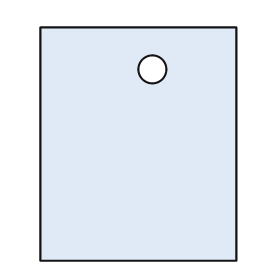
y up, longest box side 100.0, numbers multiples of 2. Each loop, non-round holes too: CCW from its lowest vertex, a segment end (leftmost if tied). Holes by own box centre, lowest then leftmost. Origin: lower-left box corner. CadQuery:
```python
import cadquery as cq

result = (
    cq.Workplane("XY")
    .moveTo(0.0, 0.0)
    .lineTo(84.0, 0.0)
    .lineTo(84.0, 100.0)
    .lineTo(0.0, 100.0)
    .close()
    .moveTo(48.0, 82.0)
    .circle(6.0)
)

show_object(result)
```